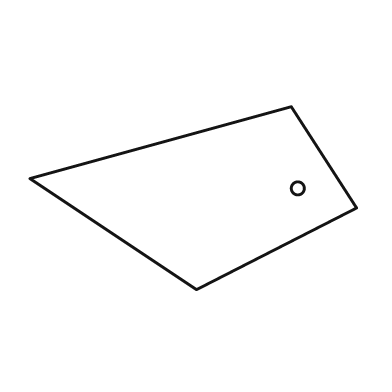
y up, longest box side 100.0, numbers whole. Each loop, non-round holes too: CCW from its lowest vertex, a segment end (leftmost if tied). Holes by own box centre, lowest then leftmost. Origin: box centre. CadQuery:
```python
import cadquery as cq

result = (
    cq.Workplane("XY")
    .moveTo(1.0, -28.0)
    .lineTo(50.0, -3.0)
    .lineTo(30.0, 28.0)
    .lineTo(-50.0, 6.0)
    .close()
    .moveTo(32.0, 3.0)
    .circle(2.0)
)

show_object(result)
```